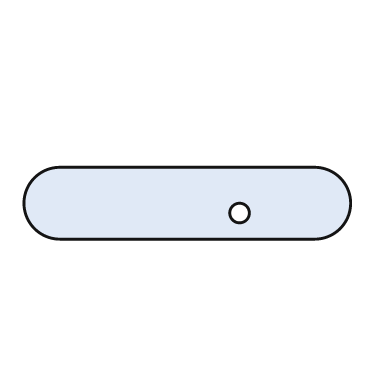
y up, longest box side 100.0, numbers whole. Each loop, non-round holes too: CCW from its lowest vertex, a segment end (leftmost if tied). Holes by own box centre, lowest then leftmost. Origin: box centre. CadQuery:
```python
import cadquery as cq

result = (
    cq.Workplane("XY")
    .moveTo(-39.0, -11.0)
    .lineTo(39.0, -11.0)
    .threePointArc((50.0, 0.0), (39.0, 11.0))
    .lineTo(-39.0, 11.0)
    .threePointArc((-50.0, 0.0), (-39.0, -11.0))
    .close()
    .moveTo(16.0, -3.0)
    .circle(3.0)
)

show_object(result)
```